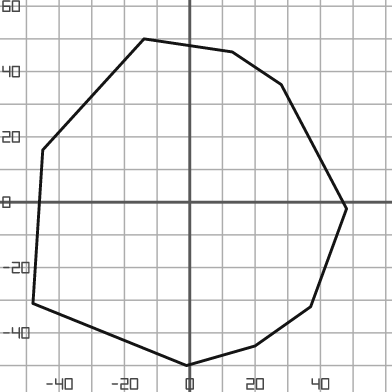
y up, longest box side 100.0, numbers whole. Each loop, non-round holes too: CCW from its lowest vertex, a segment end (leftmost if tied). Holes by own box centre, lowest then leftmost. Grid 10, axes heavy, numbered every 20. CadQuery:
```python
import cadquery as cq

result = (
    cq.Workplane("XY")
    .moveTo(-1.0, -50.0)
    .lineTo(20.0, -44.0)
    .lineTo(37.0, -32.0)
    .lineTo(48.0, -2.0)
    .lineTo(28.0, 36.0)
    .lineTo(13.0, 46.0)
    .lineTo(-14.0, 50.0)
    .lineTo(-45.0, 16.0)
    .lineTo(-48.0, -31.0)
    .close()
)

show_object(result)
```